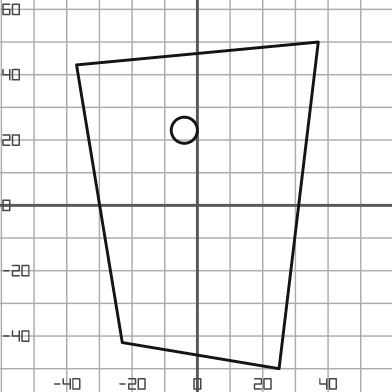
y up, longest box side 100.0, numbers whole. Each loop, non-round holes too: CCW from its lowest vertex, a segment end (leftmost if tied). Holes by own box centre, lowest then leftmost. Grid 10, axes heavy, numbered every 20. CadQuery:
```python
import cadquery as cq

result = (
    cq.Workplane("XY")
    .moveTo(25.0, -50.0)
    .lineTo(37.0, 50.0)
    .lineTo(-37.0, 43.0)
    .lineTo(-23.0, -42.0)
    .close()
    .moveTo(-4.0, 23.0)
    .circle(4.0)
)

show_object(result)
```